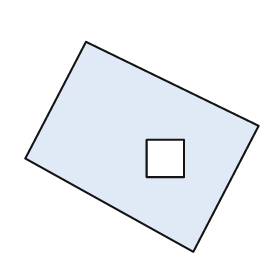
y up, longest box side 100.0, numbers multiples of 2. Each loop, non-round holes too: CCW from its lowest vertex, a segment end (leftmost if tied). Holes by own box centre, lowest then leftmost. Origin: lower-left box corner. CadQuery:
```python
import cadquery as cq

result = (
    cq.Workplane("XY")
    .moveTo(72.0, 0.0)
    .lineTo(100.0, 54.0)
    .lineTo(26.0, 90.0)
    .lineTo(0.0, 40.0)
    .close()
    .moveTo(52.0, 32.0)
    .lineTo(68.0, 32.0)
    .lineTo(68.0, 48.0)
    .lineTo(52.0, 48.0)
    .close()
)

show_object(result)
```